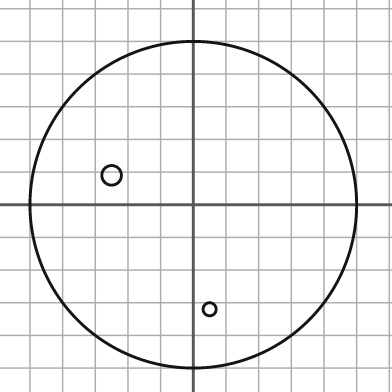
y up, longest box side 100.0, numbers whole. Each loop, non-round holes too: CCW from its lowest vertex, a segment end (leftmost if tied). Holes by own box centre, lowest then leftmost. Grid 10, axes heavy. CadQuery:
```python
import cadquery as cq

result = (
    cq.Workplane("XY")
    .moveTo(0.0, 0.0)
    .circle(50.0)
    .moveTo(5.0, -32.0)
    .circle(2.0)
    .moveTo(-25.0, 9.0)
    .circle(3.0)
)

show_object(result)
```